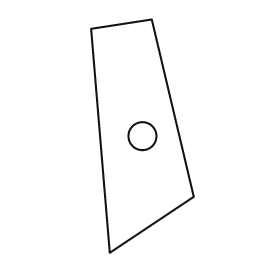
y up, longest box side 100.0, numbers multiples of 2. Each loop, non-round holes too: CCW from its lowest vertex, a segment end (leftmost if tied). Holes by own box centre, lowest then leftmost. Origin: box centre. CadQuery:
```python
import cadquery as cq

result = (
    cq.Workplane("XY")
    .moveTo(-14.0, -50.0)
    .lineTo(22.0, -26.0)
    .lineTo(4.0, 50.0)
    .lineTo(-22.0, 46.0)
    .close()
    .moveTo(0.0, 0.0)
    .circle(6.0)
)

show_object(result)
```